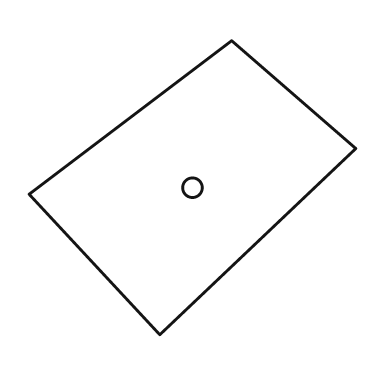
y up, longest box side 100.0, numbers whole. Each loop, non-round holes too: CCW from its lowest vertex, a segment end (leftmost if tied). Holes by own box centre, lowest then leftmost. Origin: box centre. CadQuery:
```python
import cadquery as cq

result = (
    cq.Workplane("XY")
    .moveTo(-10.0, -45.0)
    .lineTo(50.0, 12.0)
    .lineTo(12.0, 45.0)
    .lineTo(-50.0, -2.0)
    .close()
    .moveTo(0.0, 0.0)
    .circle(3.0)
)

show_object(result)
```